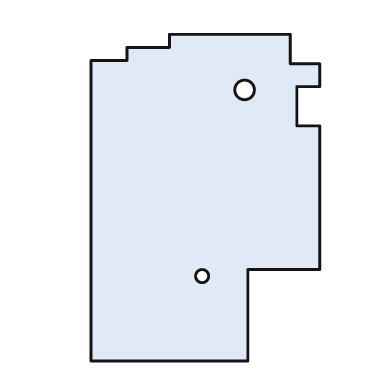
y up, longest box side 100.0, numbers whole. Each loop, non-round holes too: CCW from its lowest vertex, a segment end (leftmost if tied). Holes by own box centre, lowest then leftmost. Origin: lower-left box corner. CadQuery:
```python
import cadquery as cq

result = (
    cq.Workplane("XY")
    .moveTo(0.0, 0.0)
    .lineTo(48.0, 0.0)
    .lineTo(48.0, 28.0)
    .lineTo(70.0, 28.0)
    .lineTo(70.0, 72.0)
    .lineTo(63.0, 72.0)
    .lineTo(63.0, 84.0)
    .lineTo(70.0, 84.0)
    .lineTo(70.0, 91.0)
    .lineTo(61.0, 91.0)
    .lineTo(61.0, 100.0)
    .lineTo(24.0, 100.0)
    .lineTo(24.0, 96.0)
    .lineTo(11.0, 96.0)
    .lineTo(11.0, 92.0)
    .lineTo(0.0, 92.0)
    .close()
    .moveTo(34.0, 26.0)
    .circle(2.0)
    .moveTo(47.0, 83.0)
    .circle(3.0)
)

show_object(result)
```